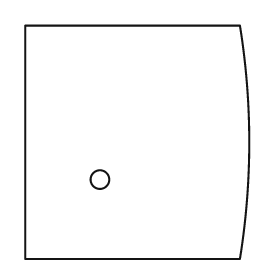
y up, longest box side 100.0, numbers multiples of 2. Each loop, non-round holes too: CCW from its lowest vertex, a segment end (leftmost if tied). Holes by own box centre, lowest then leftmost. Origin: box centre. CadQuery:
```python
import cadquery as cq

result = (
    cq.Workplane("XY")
    .moveTo(-48.0, -50.0)
    .lineTo(44.0, -50.0)
    .threePointArc((48.0, 0.0), (44.0, 50.0))
    .lineTo(-48.0, 50.0)
    .close()
    .moveTo(-16.0, -16.0)
    .circle(4.0)
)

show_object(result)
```